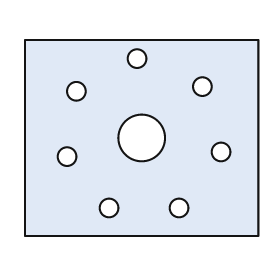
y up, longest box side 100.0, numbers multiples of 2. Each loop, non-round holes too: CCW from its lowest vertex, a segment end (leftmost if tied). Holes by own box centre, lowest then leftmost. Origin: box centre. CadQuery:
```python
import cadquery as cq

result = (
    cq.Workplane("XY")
    .moveTo(-50.0, -42.0)
    .lineTo(50.0, -42.0)
    .lineTo(50.0, 42.0)
    .lineTo(-50.0, 42.0)
    .close()
    .moveTo(-14.0, -30.0)
    .circle(4.0)
    .moveTo(16.0, -30.0)
    .circle(4.0)
    .moveTo(-32.0, -8.0)
    .circle(4.0)
    .moveTo(34.0, -6.0)
    .circle(4.0)
    .moveTo(0.0, 0.0)
    .circle(10.0)
    .moveTo(-28.0, 20.0)
    .circle(4.0)
    .moveTo(26.0, 22.0)
    .circle(4.0)
    .moveTo(-2.0, 34.0)
    .circle(4.0)
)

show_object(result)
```